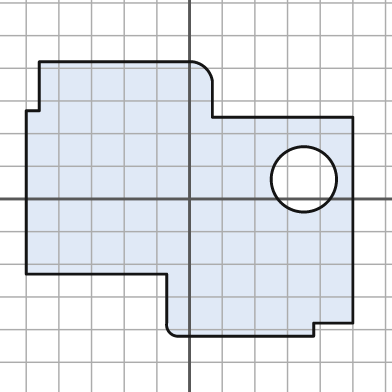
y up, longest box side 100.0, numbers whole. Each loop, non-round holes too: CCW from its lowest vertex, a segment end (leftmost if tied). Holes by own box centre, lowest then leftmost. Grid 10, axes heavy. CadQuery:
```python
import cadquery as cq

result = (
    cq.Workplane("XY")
    .moveTo(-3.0, -42.0)
    .lineTo(38.0, -42.0)
    .lineTo(38.0, -38.0)
    .lineTo(50.0, -38.0)
    .lineTo(50.0, 25.0)
    .lineTo(7.0, 25.0)
    .lineTo(7.0, 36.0)
    .threePointArc((5.0, 40.0), (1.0, 42.0))
    .lineTo(-46.0, 42.0)
    .lineTo(-46.0, 27.0)
    .lineTo(-50.0, 27.0)
    .lineTo(-50.0, -23.0)
    .lineTo(-7.0, -23.0)
    .lineTo(-7.0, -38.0)
    .threePointArc((-6.0, -41.0), (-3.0, -42.0))
    .close()
    .moveTo(35.0, 6.0)
    .circle(10.0)
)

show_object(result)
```